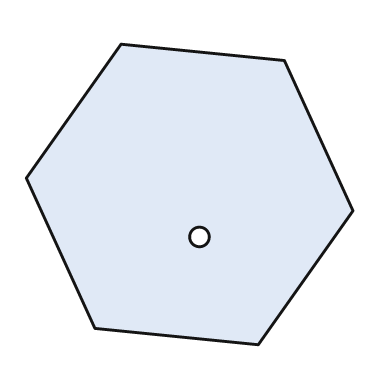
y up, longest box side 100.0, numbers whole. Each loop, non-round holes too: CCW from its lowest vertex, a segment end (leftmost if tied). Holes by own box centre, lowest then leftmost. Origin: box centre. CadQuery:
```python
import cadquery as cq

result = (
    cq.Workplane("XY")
    .moveTo(21.0, -46.0)
    .lineTo(50.0, -5.0)
    .lineTo(29.0, 41.0)
    .lineTo(-21.0, 46.0)
    .lineTo(-50.0, 5.0)
    .lineTo(-29.0, -41.0)
    .close()
    .moveTo(3.0, -13.0)
    .circle(3.0)
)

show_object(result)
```